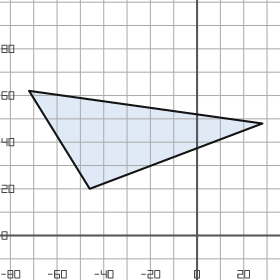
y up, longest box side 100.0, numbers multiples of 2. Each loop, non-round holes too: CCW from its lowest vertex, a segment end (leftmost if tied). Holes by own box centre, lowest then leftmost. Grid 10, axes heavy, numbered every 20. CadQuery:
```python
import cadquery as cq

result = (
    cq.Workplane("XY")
    .moveTo(-46.0, 20.0)
    .lineTo(28.0, 48.0)
    .lineTo(-72.0, 62.0)
    .close()
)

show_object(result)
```